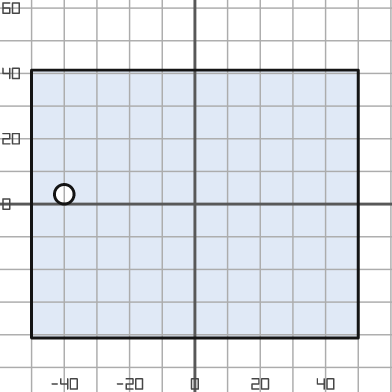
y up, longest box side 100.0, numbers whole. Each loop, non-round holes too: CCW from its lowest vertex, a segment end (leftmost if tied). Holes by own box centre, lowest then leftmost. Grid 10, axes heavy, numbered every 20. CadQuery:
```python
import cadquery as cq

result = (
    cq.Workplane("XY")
    .moveTo(-50.0, -41.0)
    .lineTo(50.0, -41.0)
    .lineTo(50.0, 41.0)
    .lineTo(-50.0, 41.0)
    .close()
    .moveTo(-40.0, 3.0)
    .circle(3.0)
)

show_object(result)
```